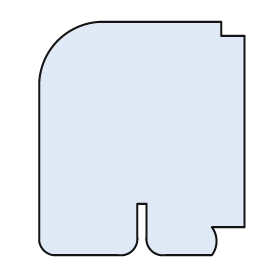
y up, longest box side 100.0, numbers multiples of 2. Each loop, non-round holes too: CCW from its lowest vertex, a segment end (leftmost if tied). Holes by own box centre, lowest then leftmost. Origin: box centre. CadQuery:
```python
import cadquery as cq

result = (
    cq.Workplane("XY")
    .moveTo(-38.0, -50.0)
    .lineTo(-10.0, -50.0)
    .threePointArc((-4.0, -48.0), (-2.0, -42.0))
    .lineTo(-2.0, -28.0)
    .lineTo(2.0, -28.0)
    .lineTo(2.0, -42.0)
    .threePointArc((4.0, -48.0), (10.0, -50.0))
    .lineTo(30.0, -50.0)
    .threePointArc((32.0, -44.0), (30.0, -38.0))
    .lineTo(44.0, -38.0)
    .lineTo(44.0, 44.0)
    .lineTo(34.0, 44.0)
    .lineTo(34.0, 50.0)
    .lineTo(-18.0, 50.0)
    .threePointArc((-36.0, 42.0), (-44.0, 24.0))
    .lineTo(-44.0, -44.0)
    .threePointArc((-42.0, -48.0), (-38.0, -50.0))
    .close()
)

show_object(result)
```